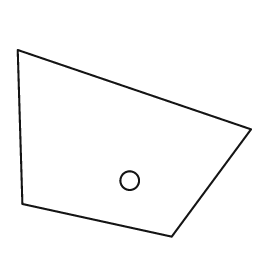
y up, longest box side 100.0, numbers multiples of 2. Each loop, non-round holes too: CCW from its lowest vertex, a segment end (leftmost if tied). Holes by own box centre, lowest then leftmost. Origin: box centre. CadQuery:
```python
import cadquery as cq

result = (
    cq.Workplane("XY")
    .moveTo(16.0, -40.0)
    .lineTo(50.0, 6.0)
    .lineTo(-50.0, 40.0)
    .lineTo(-48.0, -26.0)
    .close()
    .moveTo(-2.0, -16.0)
    .circle(4.0)
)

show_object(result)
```